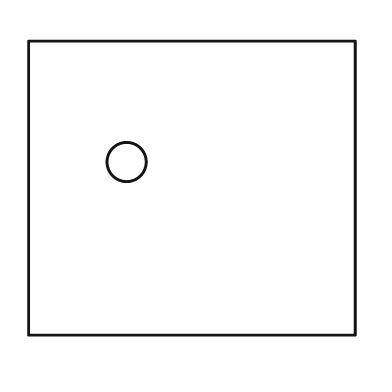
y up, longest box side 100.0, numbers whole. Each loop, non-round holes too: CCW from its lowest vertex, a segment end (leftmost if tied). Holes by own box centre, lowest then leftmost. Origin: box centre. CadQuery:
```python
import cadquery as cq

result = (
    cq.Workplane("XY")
    .moveTo(-50.0, -45.0)
    .lineTo(50.0, -45.0)
    .lineTo(50.0, 45.0)
    .lineTo(-50.0, 45.0)
    .close()
    .moveTo(-20.0, 8.0)
    .circle(6.0)
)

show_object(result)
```